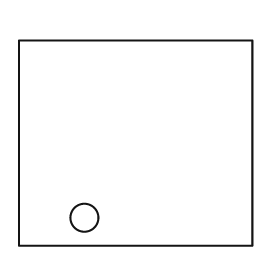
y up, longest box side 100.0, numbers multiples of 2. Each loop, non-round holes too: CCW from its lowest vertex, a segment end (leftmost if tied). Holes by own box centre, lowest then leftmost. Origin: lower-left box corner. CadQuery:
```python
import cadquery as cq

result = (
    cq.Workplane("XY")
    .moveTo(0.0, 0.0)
    .lineTo(100.0, 0.0)
    .lineTo(100.0, 88.0)
    .lineTo(0.0, 88.0)
    .close()
    .moveTo(28.0, 12.0)
    .circle(6.0)
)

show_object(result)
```